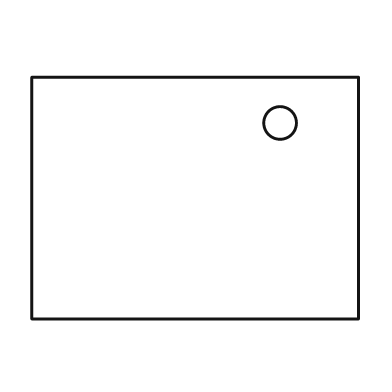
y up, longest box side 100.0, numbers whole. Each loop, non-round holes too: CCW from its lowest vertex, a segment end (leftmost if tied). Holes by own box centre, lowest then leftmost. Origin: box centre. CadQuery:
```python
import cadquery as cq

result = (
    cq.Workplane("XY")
    .moveTo(-50.0, -37.0)
    .lineTo(50.0, -37.0)
    .lineTo(50.0, 37.0)
    .lineTo(-50.0, 37.0)
    .close()
    .moveTo(26.0, 23.0)
    .circle(5.0)
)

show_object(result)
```